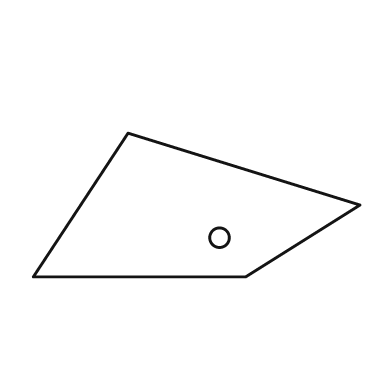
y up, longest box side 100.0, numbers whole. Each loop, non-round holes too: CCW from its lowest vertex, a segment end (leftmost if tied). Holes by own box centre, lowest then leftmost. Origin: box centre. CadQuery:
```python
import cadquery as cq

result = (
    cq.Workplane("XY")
    .moveTo(-50.0, -22.0)
    .lineTo(15.0, -22.0)
    .lineTo(50.0, 0.0)
    .lineTo(-21.0, 22.0)
    .close()
    .moveTo(7.0, -10.0)
    .circle(3.0)
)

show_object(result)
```